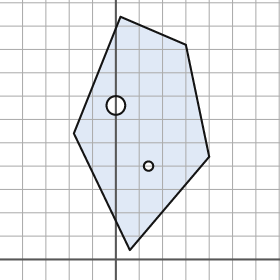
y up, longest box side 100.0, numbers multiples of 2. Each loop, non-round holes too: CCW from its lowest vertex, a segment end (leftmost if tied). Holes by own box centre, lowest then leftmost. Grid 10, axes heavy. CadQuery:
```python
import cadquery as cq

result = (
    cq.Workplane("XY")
    .moveTo(6.0, 4.0)
    .lineTo(40.0, 44.0)
    .lineTo(30.0, 92.0)
    .lineTo(2.0, 104.0)
    .lineTo(-18.0, 54.0)
    .close()
    .moveTo(14.0, 40.0)
    .circle(2.0)
    .moveTo(0.0, 66.0)
    .circle(4.0)
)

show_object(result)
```